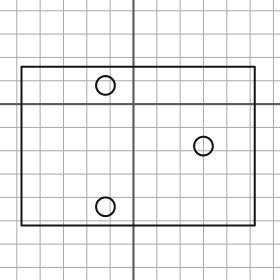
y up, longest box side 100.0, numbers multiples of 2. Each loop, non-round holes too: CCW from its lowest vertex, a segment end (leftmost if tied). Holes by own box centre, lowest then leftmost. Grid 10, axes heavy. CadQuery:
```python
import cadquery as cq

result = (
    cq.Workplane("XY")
    .moveTo(-48.0, -52.0)
    .lineTo(52.0, -52.0)
    .lineTo(52.0, 16.0)
    .lineTo(-48.0, 16.0)
    .close()
    .moveTo(-12.0, -44.0)
    .circle(4.0)
    .moveTo(30.0, -18.0)
    .circle(4.0)
    .moveTo(-12.0, 8.0)
    .circle(4.0)
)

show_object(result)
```